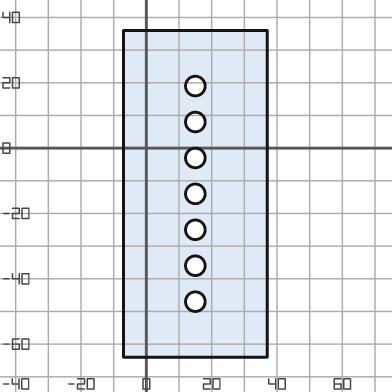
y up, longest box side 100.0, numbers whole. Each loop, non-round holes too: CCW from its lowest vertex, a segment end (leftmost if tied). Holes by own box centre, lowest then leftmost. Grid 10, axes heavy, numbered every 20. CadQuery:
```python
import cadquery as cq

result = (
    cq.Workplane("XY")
    .moveTo(-7.0, -64.0)
    .lineTo(37.0, -64.0)
    .lineTo(37.0, 36.0)
    .lineTo(-7.0, 36.0)
    .close()
    .moveTo(15.0, -47.0)
    .circle(3.0)
    .moveTo(15.0, -36.0)
    .circle(3.0)
    .moveTo(15.0, -25.0)
    .circle(3.0)
    .moveTo(15.0, -14.0)
    .circle(3.0)
    .moveTo(15.0, -3.0)
    .circle(3.0)
    .moveTo(15.0, 8.0)
    .circle(3.0)
    .moveTo(15.0, 19.0)
    .circle(3.0)
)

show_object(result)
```